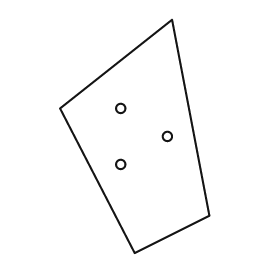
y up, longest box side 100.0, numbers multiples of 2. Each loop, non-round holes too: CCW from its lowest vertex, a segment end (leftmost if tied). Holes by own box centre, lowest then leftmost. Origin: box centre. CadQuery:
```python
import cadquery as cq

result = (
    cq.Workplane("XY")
    .moveTo(0.0, -50.0)
    .lineTo(32.0, -34.0)
    .lineTo(16.0, 50.0)
    .lineTo(-32.0, 12.0)
    .close()
    .moveTo(-6.0, -12.0)
    .circle(2.0)
    .moveTo(14.0, 0.0)
    .circle(2.0)
    .moveTo(-6.0, 12.0)
    .circle(2.0)
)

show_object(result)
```